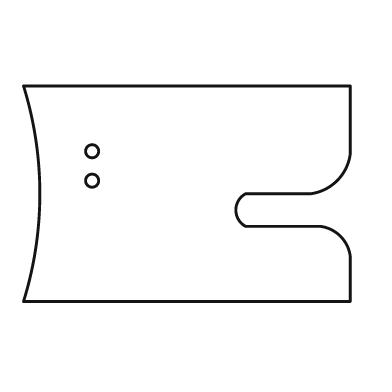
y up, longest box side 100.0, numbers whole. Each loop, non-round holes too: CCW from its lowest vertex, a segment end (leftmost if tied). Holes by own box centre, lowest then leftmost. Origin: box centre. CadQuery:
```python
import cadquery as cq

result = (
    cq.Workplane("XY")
    .moveTo(-50.0, -33.0)
    .lineTo(50.0, -33.0)
    .lineTo(50.0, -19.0)
    .threePointArc((47.0, -13.0), (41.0, -10.0))
    .lineTo(18.0, -10.0)
    .threePointArc((15.0, -5.0), (18.0, 0.0))
    .lineTo(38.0, 0.0)
    .threePointArc((46.0, 4.0), (50.0, 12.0))
    .lineTo(50.0, 33.0)
    .lineTo(-50.0, 33.0)
    .threePointArc((-45.0, 0.0), (-50.0, -33.0))
    .close()
    .moveTo(-29.0, 4.0)
    .circle(2.0)
    .moveTo(-29.0, 13.0)
    .circle(2.0)
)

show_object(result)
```